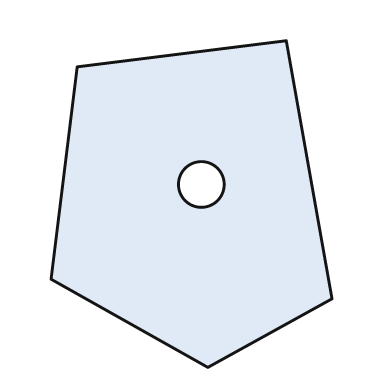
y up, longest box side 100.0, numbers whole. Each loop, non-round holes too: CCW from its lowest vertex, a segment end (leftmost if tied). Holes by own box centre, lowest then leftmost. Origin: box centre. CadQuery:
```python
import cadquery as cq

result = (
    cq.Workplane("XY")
    .moveTo(5.0, -50.0)
    .lineTo(43.0, -29.0)
    .lineTo(29.0, 50.0)
    .lineTo(-35.0, 42.0)
    .lineTo(-43.0, -23.0)
    .close()
    .moveTo(3.0, 6.0)
    .circle(7.0)
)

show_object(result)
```